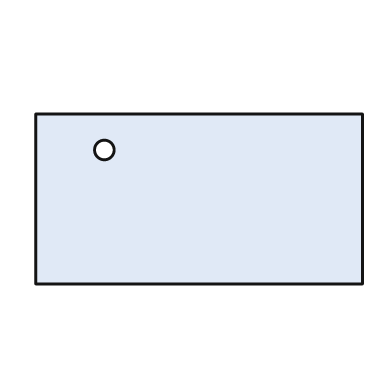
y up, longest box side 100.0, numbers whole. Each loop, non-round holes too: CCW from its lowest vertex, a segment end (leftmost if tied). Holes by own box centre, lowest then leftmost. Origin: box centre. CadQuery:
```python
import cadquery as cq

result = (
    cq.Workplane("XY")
    .moveTo(-50.0, -26.0)
    .lineTo(50.0, -26.0)
    .lineTo(50.0, 26.0)
    .lineTo(-50.0, 26.0)
    .close()
    .moveTo(-29.0, 15.0)
    .circle(3.0)
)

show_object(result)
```